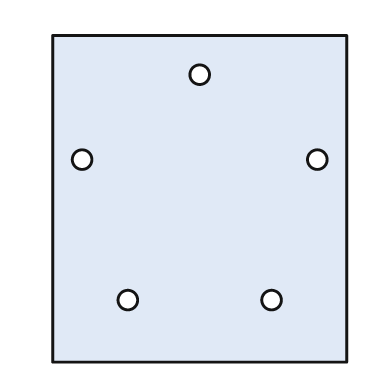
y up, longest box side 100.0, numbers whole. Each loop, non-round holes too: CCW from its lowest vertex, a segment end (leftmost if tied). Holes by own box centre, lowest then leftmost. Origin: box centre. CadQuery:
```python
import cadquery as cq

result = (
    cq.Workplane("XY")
    .moveTo(-45.0, -50.0)
    .lineTo(45.0, -50.0)
    .lineTo(45.0, 50.0)
    .lineTo(-45.0, 50.0)
    .close()
    .moveTo(-22.0, -31.0)
    .circle(3.0)
    .moveTo(22.0, -31.0)
    .circle(3.0)
    .moveTo(-36.0, 12.0)
    .circle(3.0)
    .moveTo(36.0, 12.0)
    .circle(3.0)
    .moveTo(0.0, 38.0)
    .circle(3.0)
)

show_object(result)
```